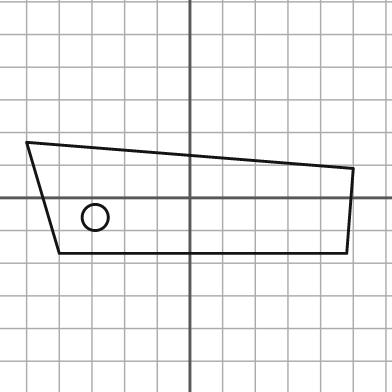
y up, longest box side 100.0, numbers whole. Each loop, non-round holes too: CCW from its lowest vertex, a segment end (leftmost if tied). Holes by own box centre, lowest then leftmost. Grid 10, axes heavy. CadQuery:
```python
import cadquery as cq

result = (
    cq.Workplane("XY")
    .moveTo(-40.0, -17.0)
    .lineTo(48.0, -17.0)
    .lineTo(50.0, 9.0)
    .lineTo(-50.0, 17.0)
    .close()
    .moveTo(-29.0, -6.0)
    .circle(4.0)
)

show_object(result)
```